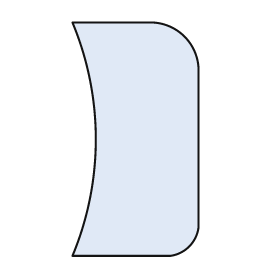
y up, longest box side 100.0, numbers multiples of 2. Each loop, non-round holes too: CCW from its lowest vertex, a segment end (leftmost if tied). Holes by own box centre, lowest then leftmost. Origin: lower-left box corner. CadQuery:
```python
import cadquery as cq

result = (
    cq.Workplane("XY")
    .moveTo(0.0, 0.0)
    .lineTo(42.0, 0.0)
    .threePointArc((50.0, 4.0), (54.0, 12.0))
    .lineTo(54.0, 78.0)
    .threePointArc((48.0, 94.0), (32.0, 100.0))
    .lineTo(0.0, 100.0)
    .threePointArc((10.0, 50.0), (0.0, 0.0))
    .close()
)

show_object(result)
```